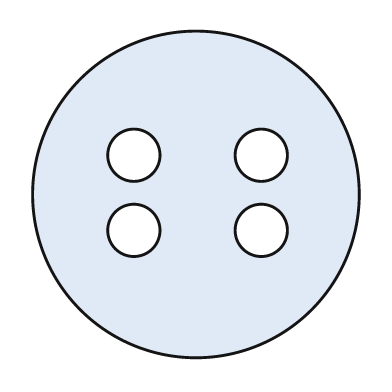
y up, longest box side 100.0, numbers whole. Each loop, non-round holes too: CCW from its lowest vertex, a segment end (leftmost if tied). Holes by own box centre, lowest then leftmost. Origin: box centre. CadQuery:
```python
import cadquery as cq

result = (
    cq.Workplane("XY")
    .moveTo(0.0, 0.0)
    .circle(50.0)
    .moveTo(-19.0, -11.0)
    .circle(8.0)
    .moveTo(20.0, -11.0)
    .circle(8.0)
    .moveTo(-19.0, 12.0)
    .circle(8.0)
    .moveTo(20.0, 12.0)
    .circle(8.0)
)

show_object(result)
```